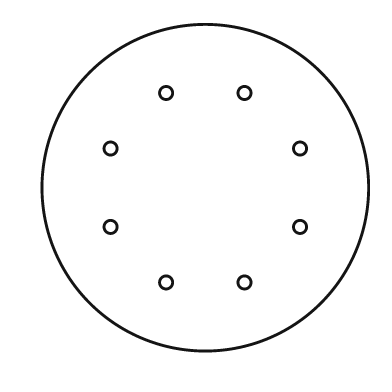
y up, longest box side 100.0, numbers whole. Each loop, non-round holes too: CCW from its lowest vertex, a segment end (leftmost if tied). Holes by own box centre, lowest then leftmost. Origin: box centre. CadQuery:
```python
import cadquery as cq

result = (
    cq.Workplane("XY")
    .moveTo(0.0, 0.0)
    .circle(50.0)
    .moveTo(-12.0, -29.0)
    .circle(2.0)
    .moveTo(12.0, -29.0)
    .circle(2.0)
    .moveTo(-29.0, -12.0)
    .circle(2.0)
    .moveTo(29.0, -12.0)
    .circle(2.0)
    .moveTo(-29.0, 12.0)
    .circle(2.0)
    .moveTo(29.0, 12.0)
    .circle(2.0)
    .moveTo(-12.0, 29.0)
    .circle(2.0)
    .moveTo(12.0, 29.0)
    .circle(2.0)
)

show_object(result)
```